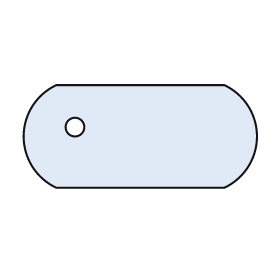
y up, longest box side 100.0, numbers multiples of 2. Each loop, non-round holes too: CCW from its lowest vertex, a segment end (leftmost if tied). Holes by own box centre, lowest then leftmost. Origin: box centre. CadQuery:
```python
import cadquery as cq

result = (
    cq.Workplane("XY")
    .moveTo(-36.0, -22.0)
    .lineTo(36.0, -22.0)
    .threePointArc((50.0, 0.0), (36.0, 22.0))
    .lineTo(-36.0, 22.0)
    .threePointArc((-50.0, 0.0), (-36.0, -22.0))
    .close()
    .moveTo(-28.0, 4.0)
    .circle(4.0)
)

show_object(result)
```